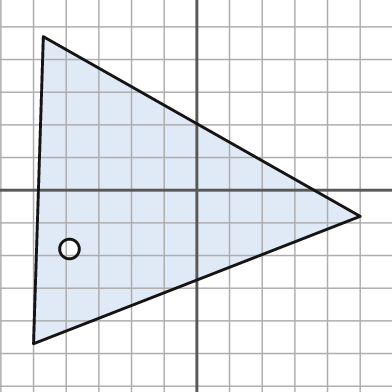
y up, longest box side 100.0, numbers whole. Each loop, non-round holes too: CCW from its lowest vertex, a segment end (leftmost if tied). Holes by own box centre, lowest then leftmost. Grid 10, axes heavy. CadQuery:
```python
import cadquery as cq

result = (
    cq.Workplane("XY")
    .moveTo(-50.0, -47.0)
    .lineTo(50.0, -8.0)
    .lineTo(-47.0, 47.0)
    .close()
    .moveTo(-39.0, -18.0)
    .circle(3.0)
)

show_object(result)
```